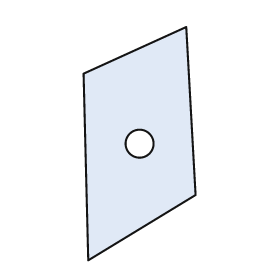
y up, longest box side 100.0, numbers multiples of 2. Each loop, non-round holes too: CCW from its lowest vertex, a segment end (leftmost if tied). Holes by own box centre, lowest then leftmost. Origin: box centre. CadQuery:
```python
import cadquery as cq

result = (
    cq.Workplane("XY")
    .moveTo(-22.0, -50.0)
    .lineTo(24.0, -22.0)
    .lineTo(20.0, 50.0)
    .lineTo(-24.0, 30.0)
    .close()
    .moveTo(0.0, 0.0)
    .circle(6.0)
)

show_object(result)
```